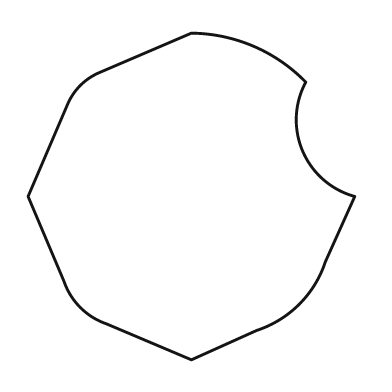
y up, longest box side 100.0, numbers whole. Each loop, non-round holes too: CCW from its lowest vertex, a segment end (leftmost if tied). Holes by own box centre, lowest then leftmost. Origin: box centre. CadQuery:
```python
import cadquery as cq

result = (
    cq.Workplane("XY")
    .moveTo(0.0, -50.0)
    .lineTo(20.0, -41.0)
    .threePointArc((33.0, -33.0), (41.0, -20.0))
    .lineTo(50.0, 0.0)
    .threePointArc((34.0, 14.0), (35.0, 35.0))
    .threePointArc((19.0, 46.0), (0.0, 50.0))
    .lineTo(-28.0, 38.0)
    .threePointArc((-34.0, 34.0), (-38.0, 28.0))
    .lineTo(-50.0, 0.0)
    .lineTo(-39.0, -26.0)
    .threePointArc((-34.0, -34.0), (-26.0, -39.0))
    .close()
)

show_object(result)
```